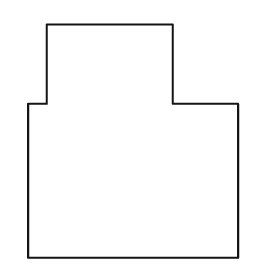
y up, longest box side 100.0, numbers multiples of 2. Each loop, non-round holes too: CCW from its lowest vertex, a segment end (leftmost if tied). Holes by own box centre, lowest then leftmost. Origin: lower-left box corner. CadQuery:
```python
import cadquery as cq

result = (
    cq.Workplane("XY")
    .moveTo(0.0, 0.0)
    .lineTo(90.0, 0.0)
    .lineTo(90.0, 66.0)
    .lineTo(62.0, 66.0)
    .lineTo(62.0, 100.0)
    .lineTo(8.0, 100.0)
    .lineTo(8.0, 66.0)
    .lineTo(0.0, 66.0)
    .close()
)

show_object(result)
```